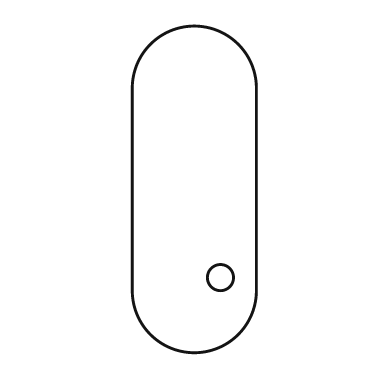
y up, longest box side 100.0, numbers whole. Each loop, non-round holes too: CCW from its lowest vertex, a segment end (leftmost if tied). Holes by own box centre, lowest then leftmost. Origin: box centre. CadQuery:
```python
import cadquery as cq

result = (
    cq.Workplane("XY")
    .moveTo(-19.0, -31.0)
    .threePointArc((0.0, -50.0), (19.0, -31.0))
    .lineTo(19.0, 31.0)
    .threePointArc((0.0, 50.0), (-19.0, 31.0))
    .close()
    .moveTo(8.0, -27.0)
    .circle(4.0)
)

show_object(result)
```